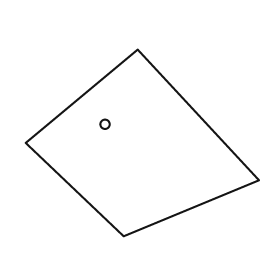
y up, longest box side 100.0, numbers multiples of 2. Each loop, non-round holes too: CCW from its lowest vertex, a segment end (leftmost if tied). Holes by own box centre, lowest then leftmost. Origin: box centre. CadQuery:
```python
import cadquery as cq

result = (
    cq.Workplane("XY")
    .moveTo(-8.0, -40.0)
    .lineTo(50.0, -16.0)
    .lineTo(-2.0, 40.0)
    .lineTo(-50.0, 0.0)
    .close()
    .moveTo(-16.0, 8.0)
    .circle(2.0)
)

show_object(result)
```